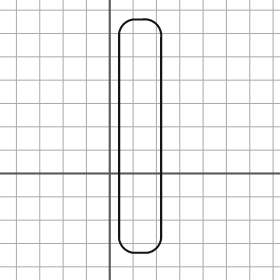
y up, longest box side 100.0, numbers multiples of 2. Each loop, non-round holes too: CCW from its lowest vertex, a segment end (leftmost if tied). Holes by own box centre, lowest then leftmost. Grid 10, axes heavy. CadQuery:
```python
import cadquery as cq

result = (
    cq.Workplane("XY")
    .moveTo(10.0, -34.0)
    .lineTo(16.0, -34.0)
    .threePointArc((20.0, -32.0), (22.0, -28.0))
    .lineTo(22.0, 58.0)
    .threePointArc((20.0, 64.0), (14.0, 66.0))
    .lineTo(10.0, 66.0)
    .threePointArc((6.0, 64.0), (4.0, 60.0))
    .lineTo(4.0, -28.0)
    .threePointArc((6.0, -32.0), (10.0, -34.0))
    .close()
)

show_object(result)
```